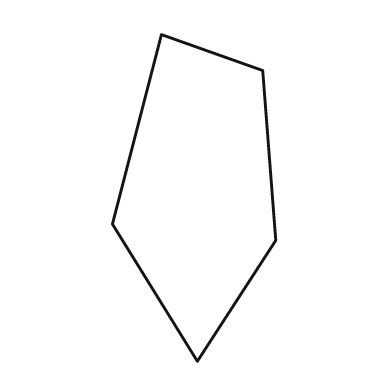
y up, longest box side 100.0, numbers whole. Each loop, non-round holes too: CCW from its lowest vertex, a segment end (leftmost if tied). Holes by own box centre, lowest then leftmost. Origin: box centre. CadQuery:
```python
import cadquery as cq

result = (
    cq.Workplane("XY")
    .moveTo(1.0, -50.0)
    .lineTo(25.0, -13.0)
    .lineTo(21.0, 39.0)
    .lineTo(-10.0, 50.0)
    .lineTo(-25.0, -8.0)
    .close()
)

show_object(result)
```